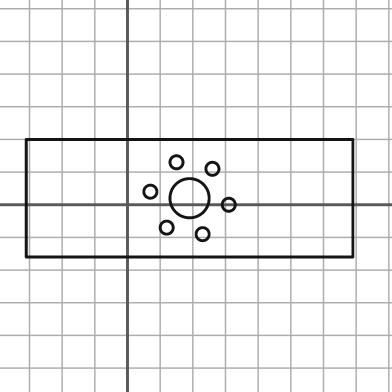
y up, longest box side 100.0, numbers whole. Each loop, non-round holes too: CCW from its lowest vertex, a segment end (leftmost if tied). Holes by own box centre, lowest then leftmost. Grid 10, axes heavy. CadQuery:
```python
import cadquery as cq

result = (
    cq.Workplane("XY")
    .moveTo(-31.0, -16.0)
    .lineTo(69.0, -16.0)
    .lineTo(69.0, 20.0)
    .lineTo(-31.0, 20.0)
    .close()
    .moveTo(23.0, -9.0)
    .circle(2.0)
    .moveTo(12.0, -7.0)
    .circle(2.0)
    .moveTo(31.0, 0.0)
    .circle(2.0)
    .moveTo(19.0, 2.0)
    .circle(6.0)
    .moveTo(7.0, 4.0)
    .circle(2.0)
    .moveTo(26.0, 11.0)
    .circle(2.0)
    .moveTo(15.0, 13.0)
    .circle(2.0)
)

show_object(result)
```